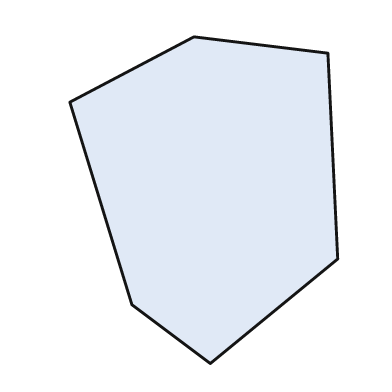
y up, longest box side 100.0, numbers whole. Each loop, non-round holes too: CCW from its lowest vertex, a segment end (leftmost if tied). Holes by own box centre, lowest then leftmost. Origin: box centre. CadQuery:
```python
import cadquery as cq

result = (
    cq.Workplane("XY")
    .moveTo(2.0, -50.0)
    .lineTo(41.0, -18.0)
    .lineTo(38.0, 45.0)
    .lineTo(-3.0, 50.0)
    .lineTo(-41.0, 30.0)
    .lineTo(-22.0, -32.0)
    .close()
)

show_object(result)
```